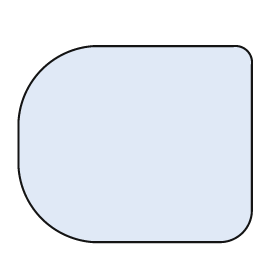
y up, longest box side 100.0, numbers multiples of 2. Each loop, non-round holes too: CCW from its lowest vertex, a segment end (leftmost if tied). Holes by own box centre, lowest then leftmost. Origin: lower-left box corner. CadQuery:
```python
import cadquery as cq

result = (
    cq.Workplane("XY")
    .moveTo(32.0, 0.0)
    .lineTo(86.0, 0.0)
    .threePointArc((96.0, 4.0), (100.0, 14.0))
    .lineTo(100.0, 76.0)
    .threePointArc((98.0, 82.0), (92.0, 84.0))
    .lineTo(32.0, 84.0)
    .threePointArc((10.0, 74.0), (0.0, 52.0))
    .lineTo(0.0, 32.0)
    .threePointArc((10.0, 10.0), (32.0, 0.0))
    .close()
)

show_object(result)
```